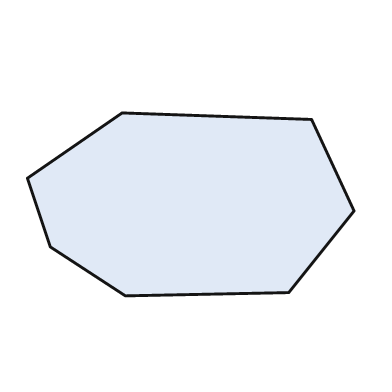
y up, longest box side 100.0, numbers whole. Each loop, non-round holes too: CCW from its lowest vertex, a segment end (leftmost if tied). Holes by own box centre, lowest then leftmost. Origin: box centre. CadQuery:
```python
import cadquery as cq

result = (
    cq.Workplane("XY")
    .moveTo(-20.0, -28.0)
    .lineTo(30.0, -27.0)
    .lineTo(50.0, -2.0)
    .lineTo(37.0, 26.0)
    .lineTo(-21.0, 28.0)
    .lineTo(-50.0, 8.0)
    .lineTo(-43.0, -13.0)
    .close()
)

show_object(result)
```